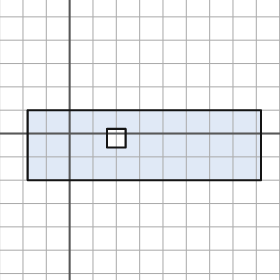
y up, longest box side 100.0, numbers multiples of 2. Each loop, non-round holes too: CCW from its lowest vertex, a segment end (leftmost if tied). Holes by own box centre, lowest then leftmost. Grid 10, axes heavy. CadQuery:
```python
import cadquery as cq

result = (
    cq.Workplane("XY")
    .moveTo(-18.0, -20.0)
    .lineTo(82.0, -20.0)
    .lineTo(82.0, 10.0)
    .lineTo(-18.0, 10.0)
    .close()
    .moveTo(16.0, -6.0)
    .lineTo(24.0, -6.0)
    .lineTo(24.0, 2.0)
    .lineTo(16.0, 2.0)
    .close()
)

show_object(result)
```